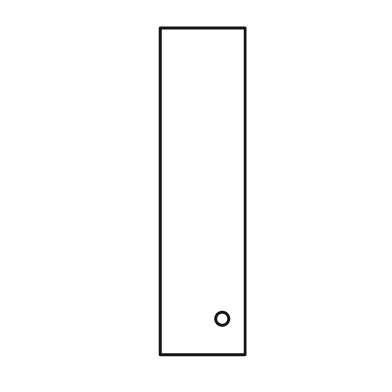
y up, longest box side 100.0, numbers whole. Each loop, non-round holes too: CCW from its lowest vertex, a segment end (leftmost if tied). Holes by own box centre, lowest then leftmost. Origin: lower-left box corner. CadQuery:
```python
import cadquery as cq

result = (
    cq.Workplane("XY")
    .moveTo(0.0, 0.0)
    .lineTo(26.0, 0.0)
    .lineTo(26.0, 100.0)
    .lineTo(0.0, 100.0)
    .close()
    .moveTo(19.0, 11.0)
    .circle(2.0)
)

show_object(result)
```